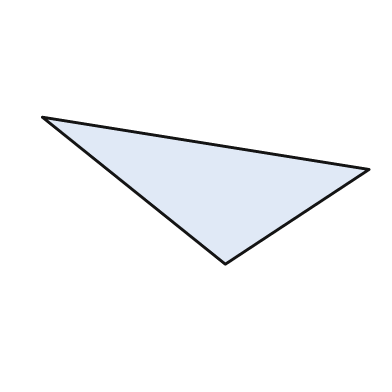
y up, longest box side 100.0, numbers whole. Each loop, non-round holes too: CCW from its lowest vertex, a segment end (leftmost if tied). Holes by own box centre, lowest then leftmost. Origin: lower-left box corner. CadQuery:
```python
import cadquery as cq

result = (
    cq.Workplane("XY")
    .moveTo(56.0, 0.0)
    .lineTo(100.0, 29.0)
    .lineTo(0.0, 45.0)
    .close()
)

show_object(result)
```